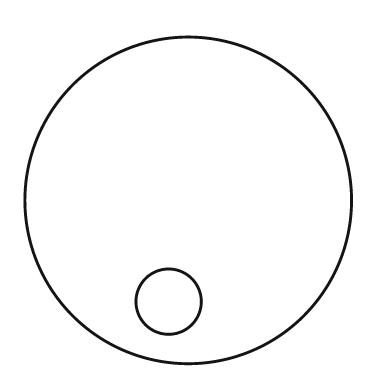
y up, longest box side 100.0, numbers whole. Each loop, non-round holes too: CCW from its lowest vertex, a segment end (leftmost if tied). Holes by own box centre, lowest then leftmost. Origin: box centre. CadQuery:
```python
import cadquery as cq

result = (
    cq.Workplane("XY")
    .moveTo(0.0, 0.0)
    .circle(50.0)
    .moveTo(-6.0, -31.0)
    .circle(10.0)
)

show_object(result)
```